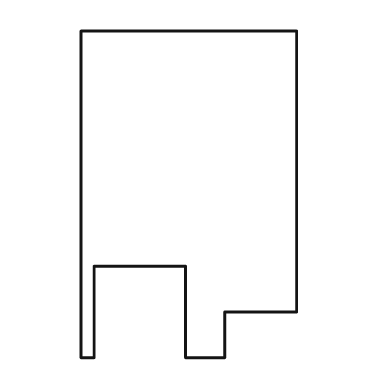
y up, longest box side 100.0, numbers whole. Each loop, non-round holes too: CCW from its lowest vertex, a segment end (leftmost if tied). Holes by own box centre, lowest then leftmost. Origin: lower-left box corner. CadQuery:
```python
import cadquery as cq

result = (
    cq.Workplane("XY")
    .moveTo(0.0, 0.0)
    .lineTo(4.0, 0.0)
    .lineTo(4.0, 28.0)
    .lineTo(32.0, 28.0)
    .lineTo(32.0, 0.0)
    .lineTo(44.0, 0.0)
    .lineTo(44.0, 14.0)
    .lineTo(66.0, 14.0)
    .lineTo(66.0, 100.0)
    .lineTo(0.0, 100.0)
    .close()
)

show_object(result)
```